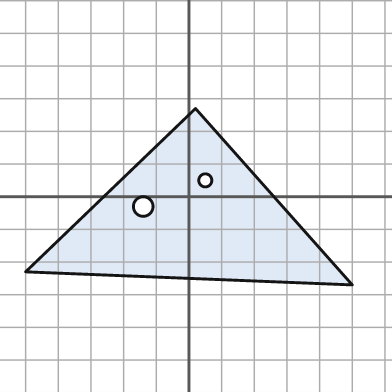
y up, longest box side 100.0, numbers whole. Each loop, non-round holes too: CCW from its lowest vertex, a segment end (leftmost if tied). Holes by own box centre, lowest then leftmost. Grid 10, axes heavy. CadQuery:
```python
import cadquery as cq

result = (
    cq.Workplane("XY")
    .moveTo(50.0, -27.0)
    .lineTo(2.0, 27.0)
    .lineTo(-50.0, -23.0)
    .close()
    .moveTo(-14.0, -3.0)
    .circle(3.0)
    .moveTo(5.0, 5.0)
    .circle(2.0)
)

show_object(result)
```